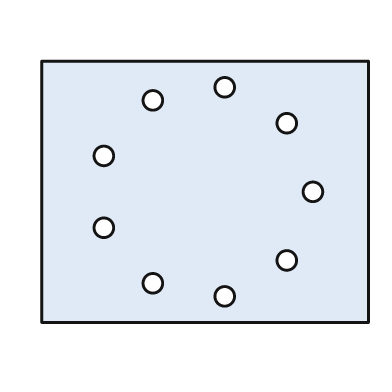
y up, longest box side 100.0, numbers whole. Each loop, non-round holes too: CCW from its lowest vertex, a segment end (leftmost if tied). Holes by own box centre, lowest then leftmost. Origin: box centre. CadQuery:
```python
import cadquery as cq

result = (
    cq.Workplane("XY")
    .moveTo(-50.0, -40.0)
    .lineTo(50.0, -40.0)
    .lineTo(50.0, 40.0)
    .lineTo(-50.0, 40.0)
    .close()
    .moveTo(6.0, -32.0)
    .circle(3.0)
    .moveTo(-16.0, -28.0)
    .circle(3.0)
    .moveTo(25.0, -21.0)
    .circle(3.0)
    .moveTo(-31.0, -11.0)
    .circle(3.0)
    .moveTo(33.0, 0.0)
    .circle(3.0)
    .moveTo(-31.0, 11.0)
    .circle(3.0)
    .moveTo(25.0, 21.0)
    .circle(3.0)
    .moveTo(-16.0, 28.0)
    .circle(3.0)
    .moveTo(6.0, 32.0)
    .circle(3.0)
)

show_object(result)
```